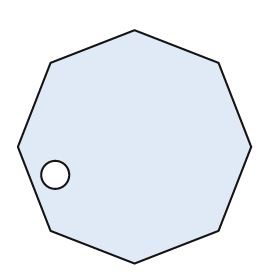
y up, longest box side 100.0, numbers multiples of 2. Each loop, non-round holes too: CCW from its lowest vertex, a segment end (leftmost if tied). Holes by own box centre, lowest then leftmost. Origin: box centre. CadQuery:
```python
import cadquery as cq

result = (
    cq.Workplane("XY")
    .moveTo(0.0, -50.0)
    .lineTo(36.0, -36.0)
    .lineTo(50.0, 0.0)
    .lineTo(36.0, 36.0)
    .lineTo(0.0, 50.0)
    .lineTo(-36.0, 36.0)
    .lineTo(-50.0, 0.0)
    .lineTo(-36.0, -36.0)
    .close()
    .moveTo(-34.0, -12.0)
    .circle(6.0)
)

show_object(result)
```